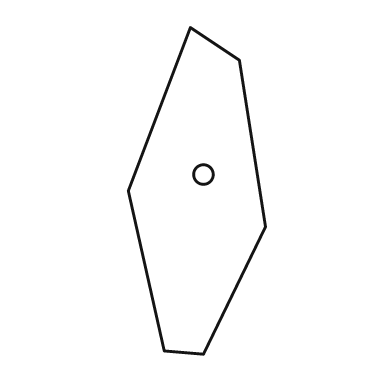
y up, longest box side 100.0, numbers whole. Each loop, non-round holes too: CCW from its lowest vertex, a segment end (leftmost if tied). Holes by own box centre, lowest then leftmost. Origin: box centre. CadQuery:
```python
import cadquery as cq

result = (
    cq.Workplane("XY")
    .moveTo(2.0, -50.0)
    .lineTo(21.0, -11.0)
    .lineTo(13.0, 40.0)
    .lineTo(-2.0, 50.0)
    .lineTo(-21.0, 0.0)
    .lineTo(-10.0, -49.0)
    .close()
    .moveTo(2.0, 5.0)
    .circle(3.0)
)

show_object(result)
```